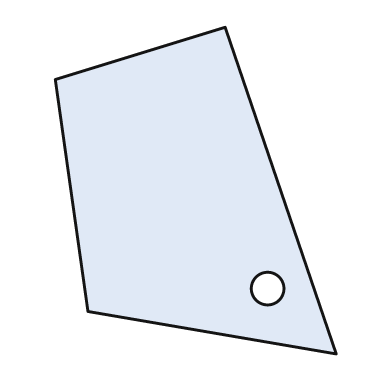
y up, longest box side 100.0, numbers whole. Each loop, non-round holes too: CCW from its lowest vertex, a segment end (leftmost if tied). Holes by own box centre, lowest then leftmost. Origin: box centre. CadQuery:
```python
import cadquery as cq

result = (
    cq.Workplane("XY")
    .moveTo(43.0, -50.0)
    .lineTo(9.0, 50.0)
    .lineTo(-43.0, 34.0)
    .lineTo(-33.0, -37.0)
    .close()
    .moveTo(22.0, -30.0)
    .circle(5.0)
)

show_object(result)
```